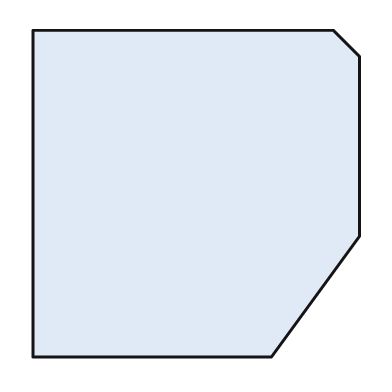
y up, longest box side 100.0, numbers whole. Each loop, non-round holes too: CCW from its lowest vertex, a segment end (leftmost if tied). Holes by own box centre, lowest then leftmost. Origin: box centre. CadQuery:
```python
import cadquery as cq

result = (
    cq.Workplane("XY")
    .moveTo(-50.0, -50.0)
    .lineTo(23.0, -50.0)
    .lineTo(50.0, -13.0)
    .lineTo(50.0, 42.0)
    .lineTo(42.0, 50.0)
    .lineTo(-50.0, 50.0)
    .close()
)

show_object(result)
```